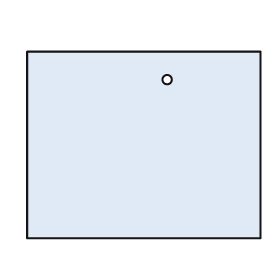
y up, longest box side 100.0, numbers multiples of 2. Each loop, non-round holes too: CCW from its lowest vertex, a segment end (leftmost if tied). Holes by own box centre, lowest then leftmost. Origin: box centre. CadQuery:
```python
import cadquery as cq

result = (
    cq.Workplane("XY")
    .moveTo(-50.0, -40.0)
    .lineTo(50.0, -40.0)
    .lineTo(50.0, 40.0)
    .lineTo(-50.0, 40.0)
    .close()
    .moveTo(10.0, 28.0)
    .circle(2.0)
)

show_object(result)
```